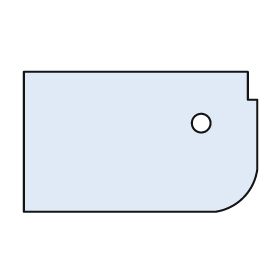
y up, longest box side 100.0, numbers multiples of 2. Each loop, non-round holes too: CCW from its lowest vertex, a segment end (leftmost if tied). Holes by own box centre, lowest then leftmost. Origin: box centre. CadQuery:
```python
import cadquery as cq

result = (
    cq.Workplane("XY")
    .moveTo(-50.0, -30.0)
    .lineTo(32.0, -30.0)
    .threePointArc((44.0, -24.0), (50.0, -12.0))
    .lineTo(50.0, 18.0)
    .lineTo(46.0, 18.0)
    .lineTo(46.0, 30.0)
    .lineTo(-50.0, 30.0)
    .close()
    .moveTo(26.0, 8.0)
    .circle(4.0)
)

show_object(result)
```